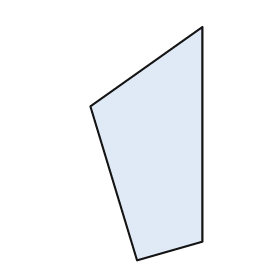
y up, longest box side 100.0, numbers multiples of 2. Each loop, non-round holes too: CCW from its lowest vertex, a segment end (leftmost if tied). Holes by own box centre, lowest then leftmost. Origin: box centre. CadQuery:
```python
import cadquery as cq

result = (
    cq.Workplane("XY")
    .moveTo(-4.0, -50.0)
    .lineTo(24.0, -42.0)
    .lineTo(24.0, 50.0)
    .lineTo(-24.0, 16.0)
    .close()
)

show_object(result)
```